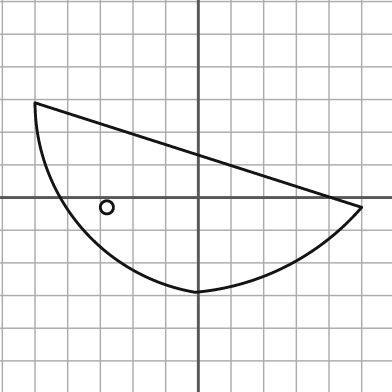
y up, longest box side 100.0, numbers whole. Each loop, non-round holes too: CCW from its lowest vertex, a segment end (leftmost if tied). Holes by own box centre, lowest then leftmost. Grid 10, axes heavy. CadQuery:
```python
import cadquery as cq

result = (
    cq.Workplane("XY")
    .moveTo(-1.0, -29.0)
    .threePointArc((27.0, -21.0), (50.0, -3.0))
    .lineTo(-50.0, 29.0)
    .threePointArc((-36.0, -9.0), (-1.0, -29.0))
    .close()
    .moveTo(-28.0, -3.0)
    .circle(2.0)
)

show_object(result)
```